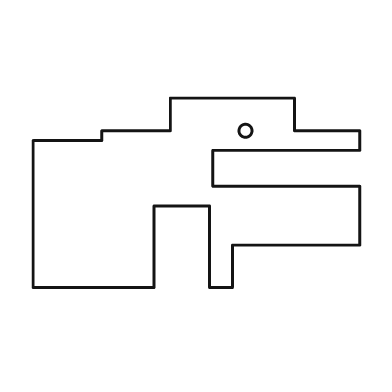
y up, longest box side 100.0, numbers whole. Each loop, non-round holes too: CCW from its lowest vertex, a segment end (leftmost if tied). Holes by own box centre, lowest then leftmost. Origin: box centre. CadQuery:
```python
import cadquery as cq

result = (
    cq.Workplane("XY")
    .moveTo(-50.0, -29.0)
    .lineTo(-13.0, -29.0)
    .lineTo(-13.0, -4.0)
    .lineTo(4.0, -4.0)
    .lineTo(4.0, -29.0)
    .lineTo(11.0, -29.0)
    .lineTo(11.0, -16.0)
    .lineTo(50.0, -16.0)
    .lineTo(50.0, 2.0)
    .lineTo(5.0, 2.0)
    .lineTo(5.0, 13.0)
    .lineTo(50.0, 13.0)
    .lineTo(50.0, 19.0)
    .lineTo(30.0, 19.0)
    .lineTo(30.0, 29.0)
    .lineTo(-8.0, 29.0)
    .lineTo(-8.0, 19.0)
    .lineTo(-29.0, 19.0)
    .lineTo(-29.0, 16.0)
    .lineTo(-50.0, 16.0)
    .close()
    .moveTo(15.0, 19.0)
    .circle(2.0)
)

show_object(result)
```